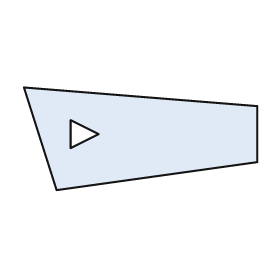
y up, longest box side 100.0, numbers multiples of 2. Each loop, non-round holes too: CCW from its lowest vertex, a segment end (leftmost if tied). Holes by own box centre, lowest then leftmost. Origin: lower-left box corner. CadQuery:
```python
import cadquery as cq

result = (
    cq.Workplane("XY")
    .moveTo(14.0, 0.0)
    .lineTo(100.0, 12.0)
    .lineTo(100.0, 36.0)
    .lineTo(0.0, 44.0)
    .close()
    .moveTo(20.0, 18.0)
    .lineTo(32.0, 24.0)
    .lineTo(20.0, 30.0)
    .close()
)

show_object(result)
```